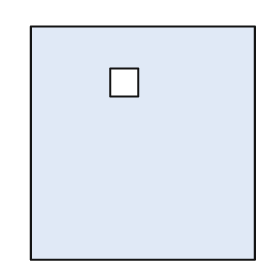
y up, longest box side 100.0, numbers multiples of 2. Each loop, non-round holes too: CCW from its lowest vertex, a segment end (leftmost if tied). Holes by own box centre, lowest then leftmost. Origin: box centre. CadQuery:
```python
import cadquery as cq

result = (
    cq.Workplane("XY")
    .moveTo(-48.0, -50.0)
    .lineTo(48.0, -50.0)
    .lineTo(48.0, 50.0)
    .lineTo(-48.0, 50.0)
    .close()
    .moveTo(-14.0, 20.0)
    .lineTo(-2.0, 20.0)
    .lineTo(-2.0, 32.0)
    .lineTo(-14.0, 32.0)
    .close()
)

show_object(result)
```